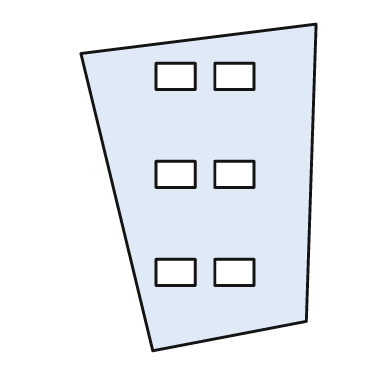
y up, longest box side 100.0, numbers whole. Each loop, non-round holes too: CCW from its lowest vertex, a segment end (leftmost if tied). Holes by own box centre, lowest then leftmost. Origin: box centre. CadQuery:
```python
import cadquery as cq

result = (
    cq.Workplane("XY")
    .moveTo(-14.0, -50.0)
    .lineTo(33.0, -41.0)
    .lineTo(36.0, 50.0)
    .lineTo(-36.0, 41.0)
    .close()
    .moveTo(-13.0, -30.0)
    .lineTo(-1.0, -30.0)
    .lineTo(-1.0, -22.0)
    .lineTo(-13.0, -22.0)
    .close()
    .moveTo(5.0, -30.0)
    .lineTo(17.0, -30.0)
    .lineTo(17.0, -22.0)
    .lineTo(5.0, -22.0)
    .close()
    .moveTo(-13.0, 0.0)
    .lineTo(-1.0, 0.0)
    .lineTo(-1.0, 8.0)
    .lineTo(-13.0, 8.0)
    .close()
    .moveTo(5.0, 0.0)
    .lineTo(17.0, 0.0)
    .lineTo(17.0, 8.0)
    .lineTo(5.0, 8.0)
    .close()
    .moveTo(-13.0, 30.0)
    .lineTo(-1.0, 30.0)
    .lineTo(-1.0, 38.0)
    .lineTo(-13.0, 38.0)
    .close()
    .moveTo(5.0, 30.0)
    .lineTo(17.0, 30.0)
    .lineTo(17.0, 38.0)
    .lineTo(5.0, 38.0)
    .close()
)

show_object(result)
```